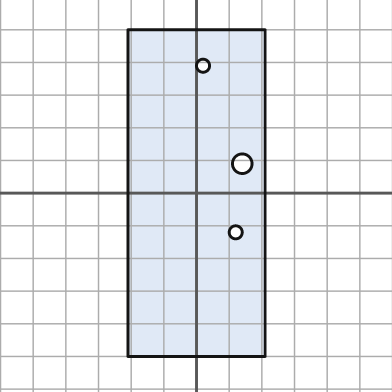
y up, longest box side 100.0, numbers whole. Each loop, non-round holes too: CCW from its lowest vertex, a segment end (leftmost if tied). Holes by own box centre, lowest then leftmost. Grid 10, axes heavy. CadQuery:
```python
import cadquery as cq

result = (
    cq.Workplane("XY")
    .moveTo(-21.0, -50.0)
    .lineTo(21.0, -50.0)
    .lineTo(21.0, 50.0)
    .lineTo(-21.0, 50.0)
    .close()
    .moveTo(12.0, -12.0)
    .circle(2.0)
    .moveTo(14.0, 9.0)
    .circle(3.0)
    .moveTo(2.0, 39.0)
    .circle(2.0)
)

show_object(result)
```